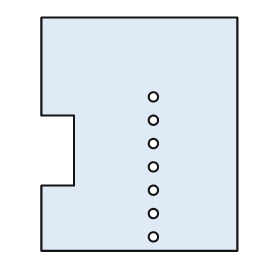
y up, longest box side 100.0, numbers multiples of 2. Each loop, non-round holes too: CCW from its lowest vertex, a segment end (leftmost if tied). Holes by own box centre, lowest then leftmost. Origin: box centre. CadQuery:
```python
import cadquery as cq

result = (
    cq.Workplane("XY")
    .moveTo(-42.0, -50.0)
    .lineTo(42.0, -50.0)
    .lineTo(42.0, 50.0)
    .lineTo(-42.0, 50.0)
    .lineTo(-42.0, 8.0)
    .lineTo(-28.0, 8.0)
    .lineTo(-28.0, -22.0)
    .lineTo(-42.0, -22.0)
    .close()
    .moveTo(6.0, -44.0)
    .circle(2.0)
    .moveTo(6.0, -34.0)
    .circle(2.0)
    .moveTo(6.0, -24.0)
    .circle(2.0)
    .moveTo(6.0, -14.0)
    .circle(2.0)
    .moveTo(6.0, -4.0)
    .circle(2.0)
    .moveTo(6.0, 6.0)
    .circle(2.0)
    .moveTo(6.0, 16.0)
    .circle(2.0)
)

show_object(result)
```